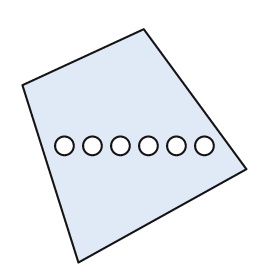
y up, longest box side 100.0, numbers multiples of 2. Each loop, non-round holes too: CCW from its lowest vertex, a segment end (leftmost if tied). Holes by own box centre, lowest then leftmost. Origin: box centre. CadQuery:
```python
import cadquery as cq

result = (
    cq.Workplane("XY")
    .moveTo(-24.0, -50.0)
    .lineTo(48.0, -10.0)
    .lineTo(4.0, 50.0)
    .lineTo(-48.0, 26.0)
    .close()
    .moveTo(-30.0, 0.0)
    .circle(4.0)
    .moveTo(-18.0, 0.0)
    .circle(4.0)
    .moveTo(-6.0, 0.0)
    .circle(4.0)
    .moveTo(6.0, 0.0)
    .circle(4.0)
    .moveTo(18.0, 0.0)
    .circle(4.0)
    .moveTo(30.0, 0.0)
    .circle(4.0)
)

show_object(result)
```